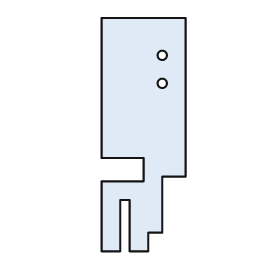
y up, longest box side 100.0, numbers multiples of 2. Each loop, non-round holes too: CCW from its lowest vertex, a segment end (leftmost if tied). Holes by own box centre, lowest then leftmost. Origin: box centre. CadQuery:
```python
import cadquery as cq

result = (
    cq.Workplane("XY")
    .moveTo(-18.0, -50.0)
    .lineTo(-10.0, -50.0)
    .lineTo(-10.0, -28.0)
    .lineTo(-6.0, -28.0)
    .lineTo(-6.0, -50.0)
    .lineTo(2.0, -50.0)
    .lineTo(2.0, -42.0)
    .lineTo(8.0, -42.0)
    .lineTo(8.0, -18.0)
    .lineTo(18.0, -18.0)
    .lineTo(18.0, 50.0)
    .lineTo(-18.0, 50.0)
    .lineTo(-18.0, -10.0)
    .lineTo(0.0, -10.0)
    .lineTo(0.0, -20.0)
    .lineTo(-18.0, -20.0)
    .close()
    .moveTo(8.0, 22.0)
    .circle(2.0)
    .moveTo(8.0, 34.0)
    .circle(2.0)
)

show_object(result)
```